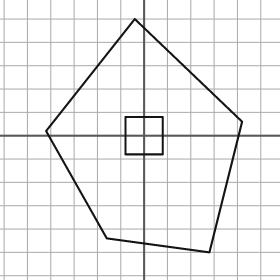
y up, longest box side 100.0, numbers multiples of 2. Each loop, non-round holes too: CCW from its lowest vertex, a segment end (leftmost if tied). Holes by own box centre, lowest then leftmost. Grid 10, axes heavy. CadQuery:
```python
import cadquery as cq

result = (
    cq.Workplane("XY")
    .moveTo(28.0, -50.0)
    .lineTo(42.0, 6.0)
    .lineTo(-4.0, 50.0)
    .lineTo(-42.0, 2.0)
    .lineTo(-16.0, -44.0)
    .close()
    .moveTo(-8.0, -8.0)
    .lineTo(8.0, -8.0)
    .lineTo(8.0, 8.0)
    .lineTo(-8.0, 8.0)
    .close()
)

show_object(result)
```